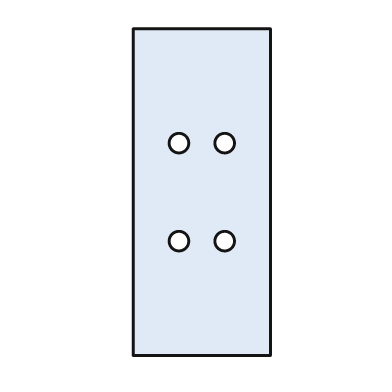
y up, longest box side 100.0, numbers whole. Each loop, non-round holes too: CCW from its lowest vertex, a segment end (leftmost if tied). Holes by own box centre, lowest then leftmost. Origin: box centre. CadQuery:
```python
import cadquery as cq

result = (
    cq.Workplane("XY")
    .moveTo(-21.0, -50.0)
    .lineTo(21.0, -50.0)
    .lineTo(21.0, 50.0)
    .lineTo(-21.0, 50.0)
    .close()
    .moveTo(-7.0, -15.0)
    .circle(3.0)
    .moveTo(7.0, -15.0)
    .circle(3.0)
    .moveTo(-7.0, 15.0)
    .circle(3.0)
    .moveTo(7.0, 15.0)
    .circle(3.0)
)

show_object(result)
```